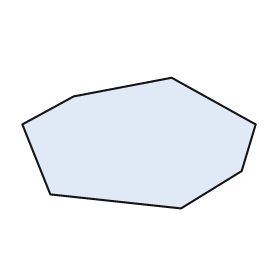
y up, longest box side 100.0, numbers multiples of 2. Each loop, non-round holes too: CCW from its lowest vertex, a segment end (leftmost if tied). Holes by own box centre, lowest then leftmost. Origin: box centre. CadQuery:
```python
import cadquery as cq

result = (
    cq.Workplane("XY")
    .moveTo(18.0, -28.0)
    .lineTo(44.0, -12.0)
    .lineTo(50.0, 8.0)
    .lineTo(14.0, 28.0)
    .lineTo(-28.0, 20.0)
    .lineTo(-50.0, 8.0)
    .lineTo(-38.0, -22.0)
    .close()
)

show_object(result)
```